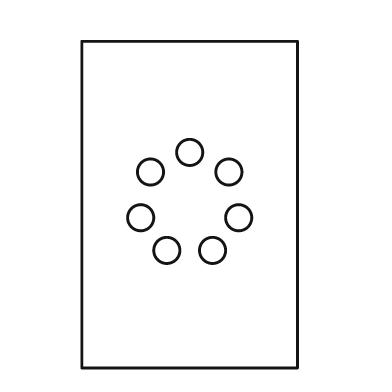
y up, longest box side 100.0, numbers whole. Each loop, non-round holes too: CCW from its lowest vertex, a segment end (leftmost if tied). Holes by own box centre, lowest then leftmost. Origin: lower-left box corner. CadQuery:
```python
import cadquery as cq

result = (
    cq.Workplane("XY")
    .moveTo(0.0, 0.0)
    .lineTo(66.0, 0.0)
    .lineTo(66.0, 100.0)
    .lineTo(0.0, 100.0)
    .close()
    .moveTo(26.0, 36.0)
    .circle(4.0)
    .moveTo(40.0, 36.0)
    .circle(4.0)
    .moveTo(18.0, 46.0)
    .circle(4.0)
    .moveTo(48.0, 46.0)
    .circle(4.0)
    .moveTo(21.0, 60.0)
    .circle(4.0)
    .moveTo(45.0, 60.0)
    .circle(4.0)
    .moveTo(33.0, 66.0)
    .circle(4.0)
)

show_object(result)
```